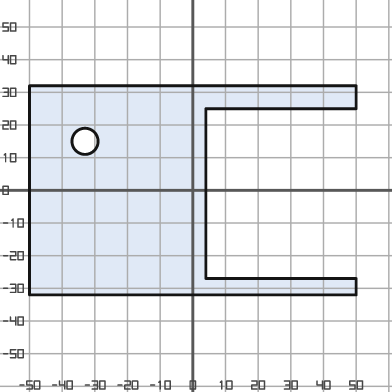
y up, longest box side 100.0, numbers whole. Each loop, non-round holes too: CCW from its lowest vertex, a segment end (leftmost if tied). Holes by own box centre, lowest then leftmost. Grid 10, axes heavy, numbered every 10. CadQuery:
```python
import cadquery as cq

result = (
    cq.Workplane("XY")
    .moveTo(-50.0, -32.0)
    .lineTo(50.0, -32.0)
    .lineTo(50.0, -27.0)
    .lineTo(4.0, -27.0)
    .lineTo(4.0, 25.0)
    .lineTo(50.0, 25.0)
    .lineTo(50.0, 32.0)
    .lineTo(-50.0, 32.0)
    .close()
    .moveTo(-33.0, 15.0)
    .circle(4.0)
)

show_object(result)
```